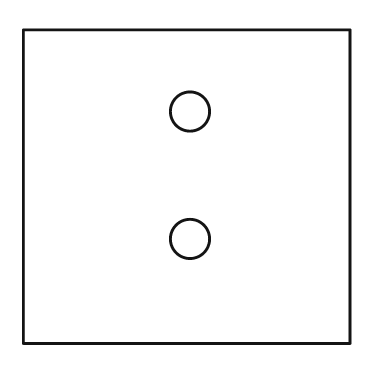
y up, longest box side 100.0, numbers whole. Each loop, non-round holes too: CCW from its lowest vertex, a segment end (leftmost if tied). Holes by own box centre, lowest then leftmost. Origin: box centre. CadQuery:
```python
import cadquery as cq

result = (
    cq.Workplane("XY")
    .moveTo(-50.0, -48.0)
    .lineTo(50.0, -48.0)
    .lineTo(50.0, 48.0)
    .lineTo(-50.0, 48.0)
    .close()
    .moveTo(1.0, -16.0)
    .circle(6.0)
    .moveTo(1.0, 23.0)
    .circle(6.0)
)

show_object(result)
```